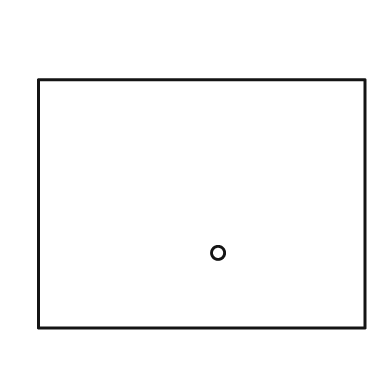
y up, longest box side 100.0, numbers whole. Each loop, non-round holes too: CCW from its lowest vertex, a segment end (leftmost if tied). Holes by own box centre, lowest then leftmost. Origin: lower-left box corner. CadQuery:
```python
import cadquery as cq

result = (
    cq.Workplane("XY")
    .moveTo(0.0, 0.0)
    .lineTo(100.0, 0.0)
    .lineTo(100.0, 76.0)
    .lineTo(0.0, 76.0)
    .close()
    .moveTo(55.0, 23.0)
    .circle(2.0)
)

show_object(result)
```